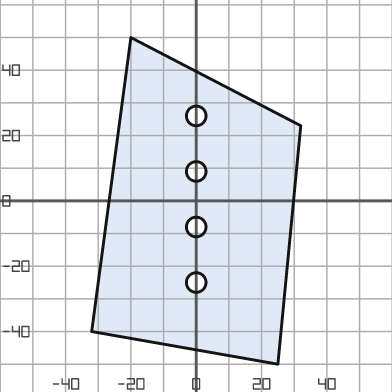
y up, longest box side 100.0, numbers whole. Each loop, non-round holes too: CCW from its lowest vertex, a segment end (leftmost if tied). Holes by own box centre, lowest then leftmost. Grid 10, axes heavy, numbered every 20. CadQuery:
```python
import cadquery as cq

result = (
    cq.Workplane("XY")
    .moveTo(25.0, -50.0)
    .lineTo(32.0, 23.0)
    .lineTo(-20.0, 50.0)
    .lineTo(-32.0, -40.0)
    .close()
    .moveTo(0.0, -25.0)
    .circle(3.0)
    .moveTo(0.0, -8.0)
    .circle(3.0)
    .moveTo(0.0, 9.0)
    .circle(3.0)
    .moveTo(0.0, 26.0)
    .circle(3.0)
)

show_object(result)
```